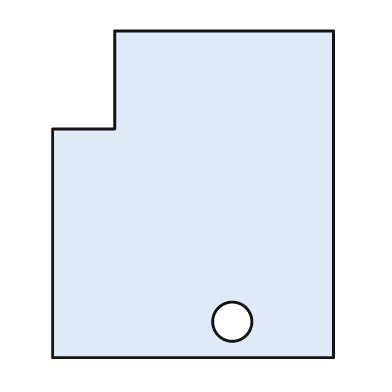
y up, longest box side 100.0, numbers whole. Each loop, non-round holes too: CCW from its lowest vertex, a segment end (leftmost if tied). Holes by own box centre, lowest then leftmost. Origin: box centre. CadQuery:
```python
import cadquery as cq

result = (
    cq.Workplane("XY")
    .moveTo(-43.0, -50.0)
    .lineTo(43.0, -50.0)
    .lineTo(43.0, 50.0)
    .lineTo(-24.0, 50.0)
    .lineTo(-24.0, 20.0)
    .lineTo(-43.0, 20.0)
    .close()
    .moveTo(12.0, -39.0)
    .circle(6.0)
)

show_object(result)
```